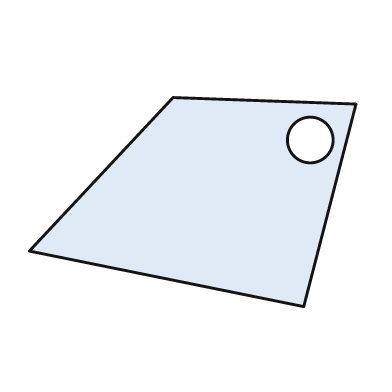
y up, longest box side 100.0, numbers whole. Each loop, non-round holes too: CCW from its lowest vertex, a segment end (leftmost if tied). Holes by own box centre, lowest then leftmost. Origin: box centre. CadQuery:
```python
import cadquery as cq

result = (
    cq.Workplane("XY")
    .moveTo(34.0, -32.0)
    .lineTo(50.0, 30.0)
    .lineTo(-6.0, 32.0)
    .lineTo(-50.0, -15.0)
    .close()
    .moveTo(36.0, 19.0)
    .circle(7.0)
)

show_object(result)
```